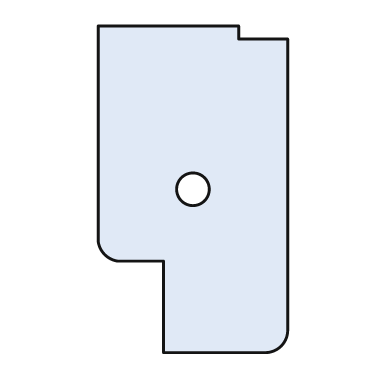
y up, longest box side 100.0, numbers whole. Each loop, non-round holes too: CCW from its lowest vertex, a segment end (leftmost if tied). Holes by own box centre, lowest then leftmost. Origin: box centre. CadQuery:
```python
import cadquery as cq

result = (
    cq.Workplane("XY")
    .moveTo(-9.0, -50.0)
    .lineTo(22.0, -50.0)
    .threePointArc((27.0, -48.0), (29.0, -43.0))
    .lineTo(29.0, 46.0)
    .lineTo(14.0, 46.0)
    .lineTo(14.0, 50.0)
    .lineTo(-29.0, 50.0)
    .lineTo(-29.0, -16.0)
    .threePointArc((-27.0, -20.0), (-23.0, -22.0))
    .lineTo(-9.0, -22.0)
    .close()
    .moveTo(0.0, 0.0)
    .circle(5.0)
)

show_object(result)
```